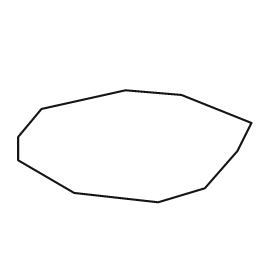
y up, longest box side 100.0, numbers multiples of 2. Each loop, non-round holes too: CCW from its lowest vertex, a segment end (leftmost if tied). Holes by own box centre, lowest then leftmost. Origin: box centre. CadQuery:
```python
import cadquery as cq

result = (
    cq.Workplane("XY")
    .moveTo(10.0, -24.0)
    .lineTo(30.0, -18.0)
    .lineTo(44.0, -2.0)
    .lineTo(50.0, 10.0)
    .lineTo(20.0, 22.0)
    .lineTo(-4.0, 24.0)
    .lineTo(-40.0, 16.0)
    .lineTo(-50.0, 4.0)
    .lineTo(-50.0, -6.0)
    .lineTo(-26.0, -20.0)
    .close()
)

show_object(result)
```